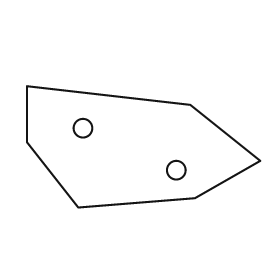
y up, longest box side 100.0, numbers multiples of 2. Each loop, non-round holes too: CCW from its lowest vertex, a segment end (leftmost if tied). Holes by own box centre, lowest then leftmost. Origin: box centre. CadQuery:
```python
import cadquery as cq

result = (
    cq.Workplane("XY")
    .moveTo(-28.0, -26.0)
    .lineTo(22.0, -22.0)
    .lineTo(50.0, -6.0)
    .lineTo(20.0, 18.0)
    .lineTo(-50.0, 26.0)
    .lineTo(-50.0, 2.0)
    .close()
    .moveTo(14.0, -10.0)
    .circle(4.0)
    .moveTo(-26.0, 8.0)
    .circle(4.0)
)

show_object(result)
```